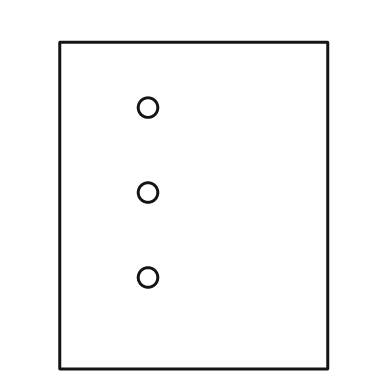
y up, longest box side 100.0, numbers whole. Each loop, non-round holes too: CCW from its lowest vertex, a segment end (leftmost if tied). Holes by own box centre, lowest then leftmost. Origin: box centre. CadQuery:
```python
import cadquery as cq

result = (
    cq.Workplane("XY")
    .moveTo(-41.0, -50.0)
    .lineTo(41.0, -50.0)
    .lineTo(41.0, 50.0)
    .lineTo(-41.0, 50.0)
    .close()
    .moveTo(-14.0, -22.0)
    .circle(3.0)
    .moveTo(-14.0, 4.0)
    .circle(3.0)
    .moveTo(-14.0, 30.0)
    .circle(3.0)
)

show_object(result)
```